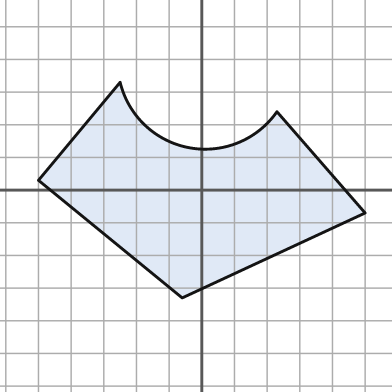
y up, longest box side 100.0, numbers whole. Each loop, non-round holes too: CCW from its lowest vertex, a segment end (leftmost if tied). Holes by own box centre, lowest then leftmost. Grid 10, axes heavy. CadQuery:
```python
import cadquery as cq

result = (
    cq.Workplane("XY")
    .moveTo(-6.0, -33.0)
    .lineTo(50.0, -7.0)
    .lineTo(23.0, 24.0)
    .threePointArc((-4.0, 13.0), (-25.0, 33.0))
    .lineTo(-50.0, 3.0)
    .close()
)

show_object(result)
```